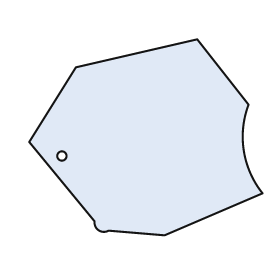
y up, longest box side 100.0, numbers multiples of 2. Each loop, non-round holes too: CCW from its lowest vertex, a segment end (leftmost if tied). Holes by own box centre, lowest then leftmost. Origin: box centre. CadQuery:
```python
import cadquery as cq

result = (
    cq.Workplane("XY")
    .moveTo(8.0, -42.0)
    .lineTo(50.0, -24.0)
    .threePointArc((42.0, -6.0), (44.0, 14.0))
    .lineTo(22.0, 42.0)
    .lineTo(-30.0, 30.0)
    .lineTo(-50.0, -2.0)
    .lineTo(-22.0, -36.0)
    .threePointArc((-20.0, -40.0), (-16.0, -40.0))
    .close()
    .moveTo(-36.0, -8.0)
    .circle(2.0)
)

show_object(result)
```